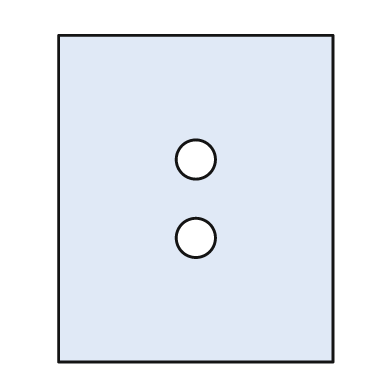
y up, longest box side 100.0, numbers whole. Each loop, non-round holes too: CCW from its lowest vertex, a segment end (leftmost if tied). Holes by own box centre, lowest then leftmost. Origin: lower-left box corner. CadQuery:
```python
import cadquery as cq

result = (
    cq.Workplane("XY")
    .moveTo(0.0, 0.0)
    .lineTo(84.0, 0.0)
    .lineTo(84.0, 100.0)
    .lineTo(0.0, 100.0)
    .close()
    .moveTo(42.0, 38.0)
    .circle(6.0)
    .moveTo(42.0, 62.0)
    .circle(6.0)
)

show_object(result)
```